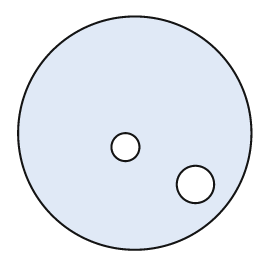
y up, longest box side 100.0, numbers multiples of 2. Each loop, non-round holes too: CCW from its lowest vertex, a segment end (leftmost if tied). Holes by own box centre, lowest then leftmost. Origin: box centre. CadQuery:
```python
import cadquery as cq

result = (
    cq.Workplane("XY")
    .moveTo(0.0, 0.0)
    .circle(50.0)
    .moveTo(26.0, -22.0)
    .circle(8.0)
    .moveTo(-4.0, -6.0)
    .circle(6.0)
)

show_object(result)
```